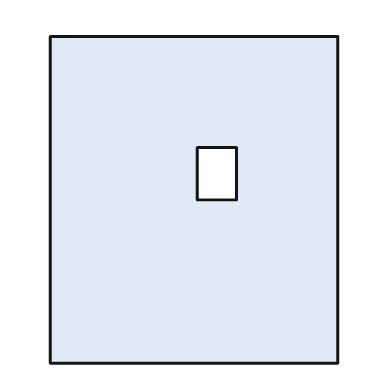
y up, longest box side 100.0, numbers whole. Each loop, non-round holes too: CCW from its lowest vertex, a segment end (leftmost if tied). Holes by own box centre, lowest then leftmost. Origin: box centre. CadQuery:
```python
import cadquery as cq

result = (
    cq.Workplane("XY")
    .moveTo(-44.0, -50.0)
    .lineTo(44.0, -50.0)
    .lineTo(44.0, 50.0)
    .lineTo(-44.0, 50.0)
    .close()
    .moveTo(1.0, 0.0)
    .lineTo(13.0, 0.0)
    .lineTo(13.0, 16.0)
    .lineTo(1.0, 16.0)
    .close()
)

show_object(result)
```